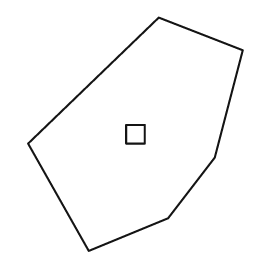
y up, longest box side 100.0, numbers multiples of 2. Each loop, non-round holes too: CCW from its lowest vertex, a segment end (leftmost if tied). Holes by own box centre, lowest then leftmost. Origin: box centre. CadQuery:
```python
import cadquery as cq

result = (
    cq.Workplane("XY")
    .moveTo(-20.0, -50.0)
    .lineTo(14.0, -36.0)
    .lineTo(34.0, -10.0)
    .lineTo(46.0, 36.0)
    .lineTo(10.0, 50.0)
    .lineTo(-46.0, -4.0)
    .close()
    .moveTo(-4.0, -4.0)
    .lineTo(4.0, -4.0)
    .lineTo(4.0, 4.0)
    .lineTo(-4.0, 4.0)
    .close()
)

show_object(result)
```